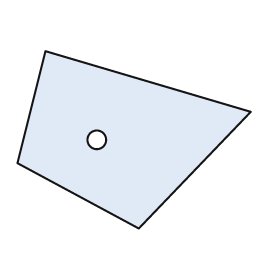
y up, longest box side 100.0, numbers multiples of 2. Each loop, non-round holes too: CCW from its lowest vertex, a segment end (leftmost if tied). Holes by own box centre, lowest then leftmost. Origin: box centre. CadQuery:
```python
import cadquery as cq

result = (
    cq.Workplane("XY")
    .moveTo(2.0, -38.0)
    .lineTo(50.0, 12.0)
    .lineTo(-38.0, 38.0)
    .lineTo(-50.0, -10.0)
    .close()
    .moveTo(-16.0, 0.0)
    .circle(4.0)
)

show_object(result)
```